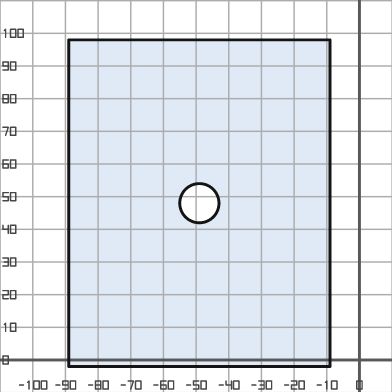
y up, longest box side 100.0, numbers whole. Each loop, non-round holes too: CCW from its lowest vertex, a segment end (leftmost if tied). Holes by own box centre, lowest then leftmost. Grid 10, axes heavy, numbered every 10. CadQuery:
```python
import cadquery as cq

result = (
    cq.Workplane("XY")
    .moveTo(-89.0, -2.0)
    .lineTo(-9.0, -2.0)
    .lineTo(-9.0, 98.0)
    .lineTo(-89.0, 98.0)
    .close()
    .moveTo(-49.0, 48.0)
    .circle(6.0)
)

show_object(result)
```